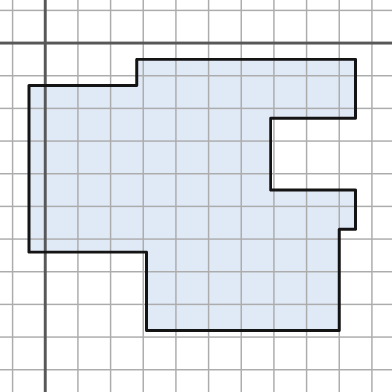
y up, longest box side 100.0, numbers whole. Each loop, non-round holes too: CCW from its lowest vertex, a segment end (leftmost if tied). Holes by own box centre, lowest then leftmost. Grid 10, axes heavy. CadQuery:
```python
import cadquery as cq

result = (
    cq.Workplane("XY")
    .moveTo(31.0, -88.0)
    .lineTo(90.0, -88.0)
    .lineTo(90.0, -57.0)
    .lineTo(95.0, -57.0)
    .lineTo(95.0, -45.0)
    .lineTo(69.0, -45.0)
    .lineTo(69.0, -23.0)
    .lineTo(95.0, -23.0)
    .lineTo(95.0, -5.0)
    .lineTo(28.0, -5.0)
    .lineTo(28.0, -13.0)
    .lineTo(-5.0, -13.0)
    .lineTo(-5.0, -64.0)
    .lineTo(31.0, -64.0)
    .close()
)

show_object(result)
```